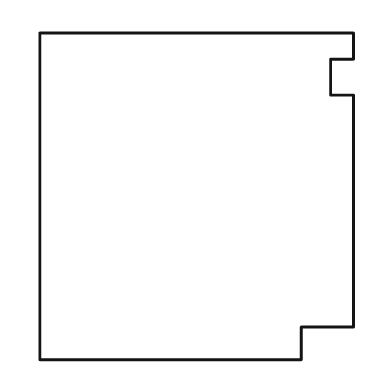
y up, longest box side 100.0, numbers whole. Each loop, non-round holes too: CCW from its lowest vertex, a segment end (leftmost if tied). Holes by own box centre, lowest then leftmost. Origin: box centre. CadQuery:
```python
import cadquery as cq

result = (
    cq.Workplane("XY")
    .moveTo(-48.0, -50.0)
    .lineTo(32.0, -50.0)
    .lineTo(32.0, -40.0)
    .lineTo(48.0, -40.0)
    .lineTo(48.0, 31.0)
    .lineTo(41.0, 31.0)
    .lineTo(41.0, 42.0)
    .lineTo(48.0, 42.0)
    .lineTo(48.0, 50.0)
    .lineTo(-48.0, 50.0)
    .close()
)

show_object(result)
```